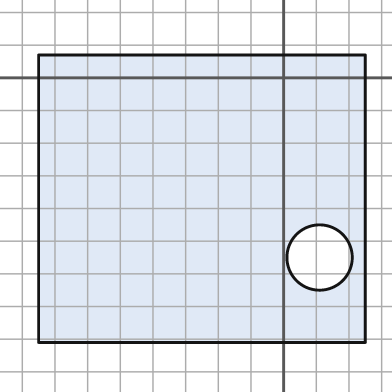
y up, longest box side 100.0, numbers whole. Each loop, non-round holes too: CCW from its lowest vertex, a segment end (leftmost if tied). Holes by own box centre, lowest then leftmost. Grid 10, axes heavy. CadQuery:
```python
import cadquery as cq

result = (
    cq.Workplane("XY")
    .moveTo(-75.0, -81.0)
    .lineTo(25.0, -81.0)
    .lineTo(25.0, 7.0)
    .lineTo(-75.0, 7.0)
    .close()
    .moveTo(11.0, -55.0)
    .circle(10.0)
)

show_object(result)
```